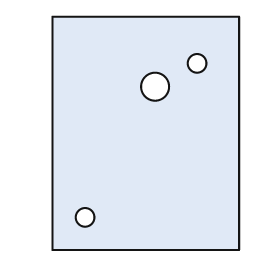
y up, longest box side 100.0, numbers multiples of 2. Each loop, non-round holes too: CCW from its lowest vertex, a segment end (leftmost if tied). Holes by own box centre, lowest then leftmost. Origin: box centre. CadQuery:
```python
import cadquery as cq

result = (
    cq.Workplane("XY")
    .moveTo(-40.0, -50.0)
    .lineTo(40.0, -50.0)
    .lineTo(40.0, 50.0)
    .lineTo(-40.0, 50.0)
    .close()
    .moveTo(-26.0, -36.0)
    .circle(4.0)
    .moveTo(4.0, 20.0)
    .circle(6.0)
    .moveTo(22.0, 30.0)
    .circle(4.0)
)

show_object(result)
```